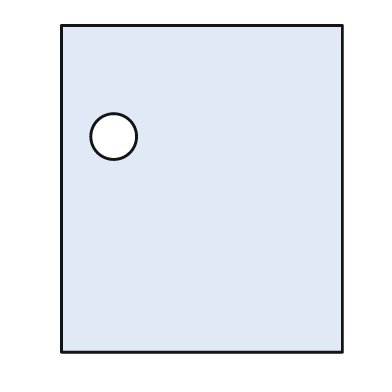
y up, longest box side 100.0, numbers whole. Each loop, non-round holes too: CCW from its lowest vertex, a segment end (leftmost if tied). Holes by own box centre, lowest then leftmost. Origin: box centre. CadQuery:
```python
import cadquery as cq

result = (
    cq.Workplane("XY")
    .moveTo(-43.0, -50.0)
    .lineTo(43.0, -50.0)
    .lineTo(43.0, 50.0)
    .lineTo(-43.0, 50.0)
    .close()
    .moveTo(-27.0, 16.0)
    .circle(7.0)
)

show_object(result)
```